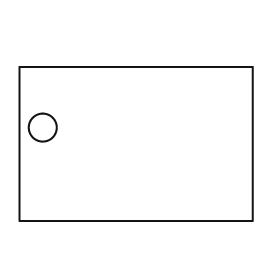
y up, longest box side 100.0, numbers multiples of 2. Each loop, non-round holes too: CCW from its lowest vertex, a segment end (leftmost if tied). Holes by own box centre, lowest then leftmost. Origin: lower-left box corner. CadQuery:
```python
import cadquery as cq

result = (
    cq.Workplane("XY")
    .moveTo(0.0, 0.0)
    .lineTo(100.0, 0.0)
    .lineTo(100.0, 66.0)
    .lineTo(0.0, 66.0)
    .close()
    .moveTo(10.0, 40.0)
    .circle(6.0)
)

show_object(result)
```